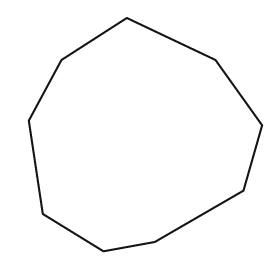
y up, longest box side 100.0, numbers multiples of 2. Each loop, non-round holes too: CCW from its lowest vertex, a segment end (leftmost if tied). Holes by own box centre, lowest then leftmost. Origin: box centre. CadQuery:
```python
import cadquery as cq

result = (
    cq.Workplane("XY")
    .moveTo(-18.0, -50.0)
    .lineTo(4.0, -46.0)
    .lineTo(42.0, -24.0)
    .lineTo(50.0, 4.0)
    .lineTo(30.0, 32.0)
    .lineTo(-8.0, 50.0)
    .lineTo(-36.0, 32.0)
    .lineTo(-50.0, 6.0)
    .lineTo(-44.0, -34.0)
    .close()
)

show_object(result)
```